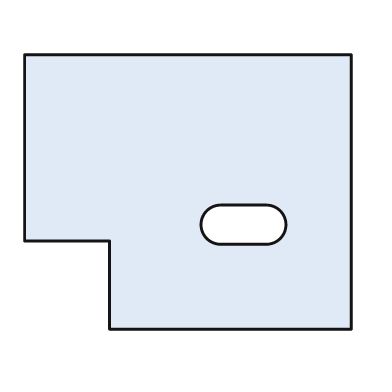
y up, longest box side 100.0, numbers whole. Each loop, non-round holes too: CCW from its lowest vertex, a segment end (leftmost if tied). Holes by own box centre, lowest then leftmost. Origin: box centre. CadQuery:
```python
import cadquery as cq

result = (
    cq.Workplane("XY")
    .moveTo(-24.0, -42.0)
    .lineTo(50.0, -42.0)
    .lineTo(50.0, 42.0)
    .lineTo(-50.0, 42.0)
    .lineTo(-50.0, -15.0)
    .lineTo(-24.0, -15.0)
    .close()
    .moveTo(10.0, -16.0)
    .lineTo(24.0, -16.0)
    .threePointArc((30.0, -10.0), (24.0, -4.0))
    .lineTo(10.0, -4.0)
    .threePointArc((4.0, -10.0), (10.0, -16.0))
    .close()
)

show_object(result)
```